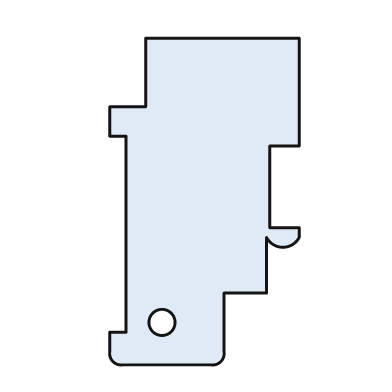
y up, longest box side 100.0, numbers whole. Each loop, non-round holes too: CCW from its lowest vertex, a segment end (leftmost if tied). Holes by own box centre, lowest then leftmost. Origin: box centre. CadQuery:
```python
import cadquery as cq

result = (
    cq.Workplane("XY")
    .moveTo(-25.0, -50.0)
    .lineTo(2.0, -50.0)
    .threePointArc((5.0, -49.0), (6.0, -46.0))
    .lineTo(6.0, -28.0)
    .lineTo(19.0, -28.0)
    .lineTo(19.0, -11.0)
    .threePointArc((24.0, -14.0), (29.0, -11.0))
    .lineTo(29.0, -8.0)
    .lineTo(20.0, -8.0)
    .lineTo(20.0, 17.0)
    .lineTo(29.0, 17.0)
    .lineTo(29.0, 50.0)
    .lineTo(-18.0, 50.0)
    .lineTo(-18.0, 29.0)
    .lineTo(-29.0, 29.0)
    .lineTo(-29.0, 20.0)
    .lineTo(-24.0, 20.0)
    .lineTo(-24.0, -40.0)
    .lineTo(-29.0, -40.0)
    .lineTo(-29.0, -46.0)
    .threePointArc((-28.0, -49.0), (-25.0, -50.0))
    .close()
    .moveTo(-13.0, -37.0)
    .circle(4.0)
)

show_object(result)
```